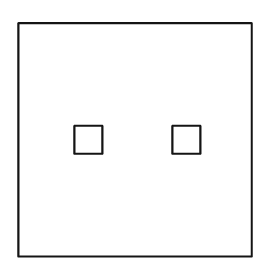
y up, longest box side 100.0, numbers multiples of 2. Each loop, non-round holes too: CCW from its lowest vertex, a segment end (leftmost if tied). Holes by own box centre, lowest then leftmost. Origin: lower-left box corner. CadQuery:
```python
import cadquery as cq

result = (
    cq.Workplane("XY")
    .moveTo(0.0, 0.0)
    .lineTo(100.0, 0.0)
    .lineTo(100.0, 100.0)
    .lineTo(0.0, 100.0)
    .close()
    .moveTo(24.0, 44.0)
    .lineTo(36.0, 44.0)
    .lineTo(36.0, 56.0)
    .lineTo(24.0, 56.0)
    .close()
    .moveTo(66.0, 44.0)
    .lineTo(78.0, 44.0)
    .lineTo(78.0, 56.0)
    .lineTo(66.0, 56.0)
    .close()
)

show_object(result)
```